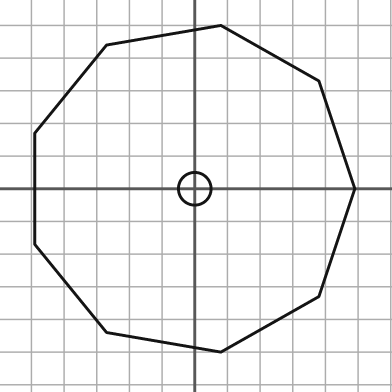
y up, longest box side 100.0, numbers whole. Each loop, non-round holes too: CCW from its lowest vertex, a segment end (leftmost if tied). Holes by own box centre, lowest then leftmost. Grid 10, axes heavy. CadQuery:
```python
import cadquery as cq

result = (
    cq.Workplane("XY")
    .moveTo(8.0, -50.0)
    .lineTo(38.0, -33.0)
    .lineTo(49.0, 0.0)
    .lineTo(38.0, 33.0)
    .lineTo(8.0, 50.0)
    .lineTo(-27.0, 44.0)
    .lineTo(-49.0, 17.0)
    .lineTo(-49.0, -17.0)
    .lineTo(-27.0, -44.0)
    .close()
    .moveTo(0.0, 0.0)
    .circle(5.0)
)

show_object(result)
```